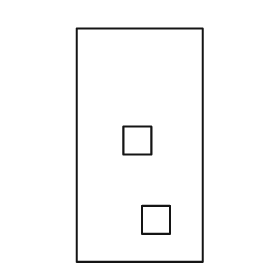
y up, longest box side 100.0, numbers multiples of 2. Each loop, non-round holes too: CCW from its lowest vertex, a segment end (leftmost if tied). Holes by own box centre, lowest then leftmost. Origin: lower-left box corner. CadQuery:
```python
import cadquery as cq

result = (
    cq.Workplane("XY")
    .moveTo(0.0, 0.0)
    .lineTo(54.0, 0.0)
    .lineTo(54.0, 100.0)
    .lineTo(0.0, 100.0)
    .close()
    .moveTo(28.0, 12.0)
    .lineTo(40.0, 12.0)
    .lineTo(40.0, 24.0)
    .lineTo(28.0, 24.0)
    .close()
    .moveTo(20.0, 46.0)
    .lineTo(32.0, 46.0)
    .lineTo(32.0, 58.0)
    .lineTo(20.0, 58.0)
    .close()
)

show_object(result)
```